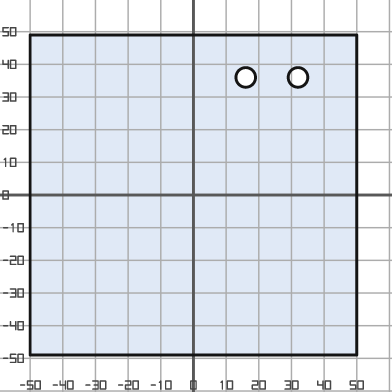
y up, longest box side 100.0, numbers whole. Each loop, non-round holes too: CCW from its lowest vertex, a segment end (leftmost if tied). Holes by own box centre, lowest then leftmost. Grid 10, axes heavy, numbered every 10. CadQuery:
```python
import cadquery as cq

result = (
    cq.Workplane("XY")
    .moveTo(-50.0, -49.0)
    .lineTo(50.0, -49.0)
    .lineTo(50.0, 49.0)
    .lineTo(-50.0, 49.0)
    .close()
    .moveTo(16.0, 36.0)
    .circle(3.0)
    .moveTo(32.0, 36.0)
    .circle(3.0)
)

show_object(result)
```